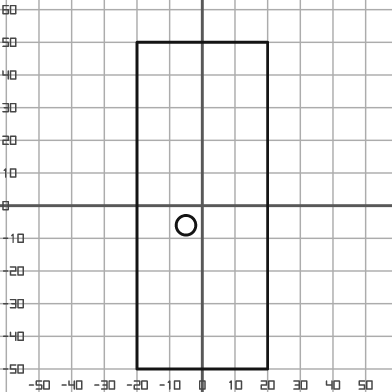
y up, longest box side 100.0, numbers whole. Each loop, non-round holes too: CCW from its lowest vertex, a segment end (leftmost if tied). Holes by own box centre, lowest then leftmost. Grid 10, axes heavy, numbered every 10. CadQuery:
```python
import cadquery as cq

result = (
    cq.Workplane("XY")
    .moveTo(-20.0, -50.0)
    .lineTo(20.0, -50.0)
    .lineTo(20.0, 50.0)
    .lineTo(-20.0, 50.0)
    .close()
    .moveTo(-5.0, -6.0)
    .circle(3.0)
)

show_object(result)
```